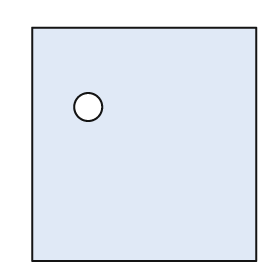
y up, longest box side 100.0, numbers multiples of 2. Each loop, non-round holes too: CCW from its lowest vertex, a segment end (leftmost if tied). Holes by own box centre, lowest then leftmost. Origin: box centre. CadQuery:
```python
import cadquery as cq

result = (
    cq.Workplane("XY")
    .moveTo(-48.0, -50.0)
    .lineTo(48.0, -50.0)
    .lineTo(48.0, 50.0)
    .lineTo(-48.0, 50.0)
    .close()
    .moveTo(-24.0, 16.0)
    .circle(6.0)
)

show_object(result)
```